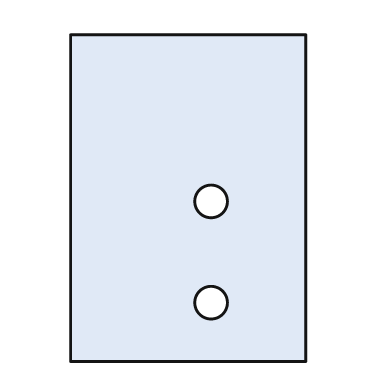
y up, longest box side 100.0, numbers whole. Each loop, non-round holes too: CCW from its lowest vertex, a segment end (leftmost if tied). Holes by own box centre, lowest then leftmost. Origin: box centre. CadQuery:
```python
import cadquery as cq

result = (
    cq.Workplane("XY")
    .moveTo(-36.0, -50.0)
    .lineTo(36.0, -50.0)
    .lineTo(36.0, 50.0)
    .lineTo(-36.0, 50.0)
    .close()
    .moveTo(7.0, -32.0)
    .circle(5.0)
    .moveTo(7.0, -1.0)
    .circle(5.0)
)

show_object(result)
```